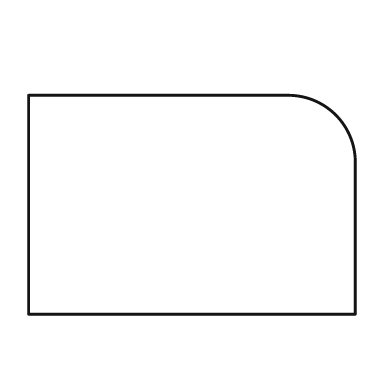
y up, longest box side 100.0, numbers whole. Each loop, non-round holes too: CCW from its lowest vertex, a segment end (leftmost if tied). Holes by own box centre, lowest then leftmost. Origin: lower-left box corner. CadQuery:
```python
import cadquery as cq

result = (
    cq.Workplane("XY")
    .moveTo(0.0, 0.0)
    .lineTo(100.0, 0.0)
    .lineTo(100.0, 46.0)
    .threePointArc((94.0, 61.0), (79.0, 67.0))
    .lineTo(0.0, 67.0)
    .close()
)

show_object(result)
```